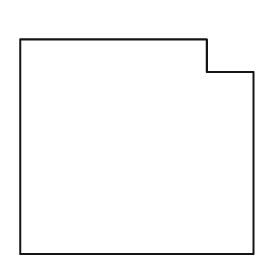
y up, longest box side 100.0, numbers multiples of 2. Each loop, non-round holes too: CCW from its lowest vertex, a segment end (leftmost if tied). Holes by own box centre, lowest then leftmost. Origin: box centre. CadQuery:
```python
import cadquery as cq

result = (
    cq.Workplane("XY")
    .moveTo(-50.0, -46.0)
    .lineTo(50.0, -46.0)
    .lineTo(50.0, 32.0)
    .lineTo(30.0, 32.0)
    .lineTo(30.0, 46.0)
    .lineTo(-50.0, 46.0)
    .close()
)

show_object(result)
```